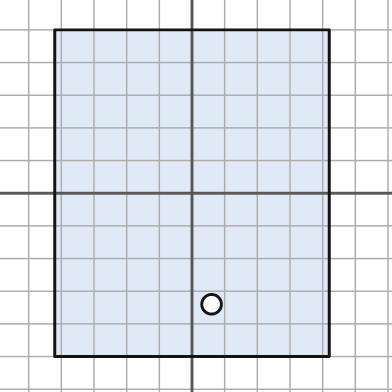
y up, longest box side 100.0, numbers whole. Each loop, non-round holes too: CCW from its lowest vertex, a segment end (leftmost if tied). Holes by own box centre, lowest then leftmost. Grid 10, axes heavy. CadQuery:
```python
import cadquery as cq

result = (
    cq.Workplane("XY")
    .moveTo(-42.0, -50.0)
    .lineTo(42.0, -50.0)
    .lineTo(42.0, 50.0)
    .lineTo(-42.0, 50.0)
    .close()
    .moveTo(6.0, -34.0)
    .circle(3.0)
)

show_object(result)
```